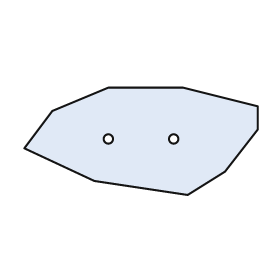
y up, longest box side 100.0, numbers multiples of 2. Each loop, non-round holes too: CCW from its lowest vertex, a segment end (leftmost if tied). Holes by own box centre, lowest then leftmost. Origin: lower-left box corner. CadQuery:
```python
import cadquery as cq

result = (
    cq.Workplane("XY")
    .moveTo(70.0, 0.0)
    .lineTo(86.0, 10.0)
    .lineTo(100.0, 28.0)
    .lineTo(100.0, 38.0)
    .lineTo(68.0, 46.0)
    .lineTo(36.0, 46.0)
    .lineTo(12.0, 36.0)
    .lineTo(0.0, 20.0)
    .lineTo(30.0, 6.0)
    .close()
    .moveTo(36.0, 24.0)
    .circle(2.0)
    .moveTo(64.0, 24.0)
    .circle(2.0)
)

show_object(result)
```